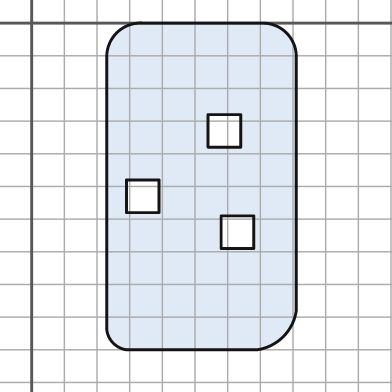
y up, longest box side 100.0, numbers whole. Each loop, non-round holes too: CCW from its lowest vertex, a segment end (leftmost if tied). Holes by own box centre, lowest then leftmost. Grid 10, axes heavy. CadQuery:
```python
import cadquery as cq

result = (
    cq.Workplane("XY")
    .moveTo(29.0, -100.0)
    .lineTo(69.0, -100.0)
    .threePointArc((77.0, -96.0), (81.0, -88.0))
    .lineTo(81.0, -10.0)
    .threePointArc((78.0, -3.0), (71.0, 0.0))
    .lineTo(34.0, 0.0)
    .threePointArc((26.0, -3.0), (23.0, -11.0))
    .lineTo(23.0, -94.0)
    .threePointArc((25.0, -98.0), (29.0, -100.0))
    .close()
    .moveTo(58.0, -69.0)
    .lineTo(68.0, -69.0)
    .lineTo(68.0, -59.0)
    .lineTo(58.0, -59.0)
    .close()
    .moveTo(29.0, -58.0)
    .lineTo(39.0, -58.0)
    .lineTo(39.0, -48.0)
    .lineTo(29.0, -48.0)
    .close()
    .moveTo(54.0, -38.0)
    .lineTo(64.0, -38.0)
    .lineTo(64.0, -28.0)
    .lineTo(54.0, -28.0)
    .close()
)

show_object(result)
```